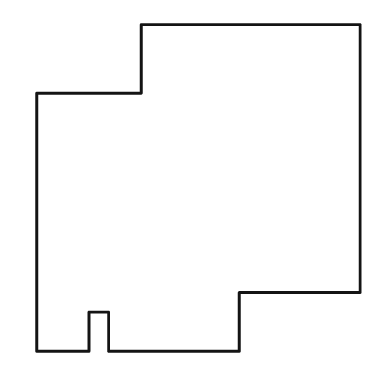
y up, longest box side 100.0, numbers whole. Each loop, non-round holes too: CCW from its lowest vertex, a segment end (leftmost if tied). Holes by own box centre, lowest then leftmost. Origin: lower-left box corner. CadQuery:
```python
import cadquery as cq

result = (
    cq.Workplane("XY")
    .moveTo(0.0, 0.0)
    .lineTo(16.0, 0.0)
    .lineTo(16.0, 12.0)
    .lineTo(22.0, 12.0)
    .lineTo(22.0, 0.0)
    .lineTo(62.0, 0.0)
    .lineTo(62.0, 18.0)
    .lineTo(99.0, 18.0)
    .lineTo(99.0, 100.0)
    .lineTo(32.0, 100.0)
    .lineTo(32.0, 79.0)
    .lineTo(0.0, 79.0)
    .close()
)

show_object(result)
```